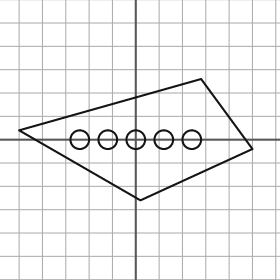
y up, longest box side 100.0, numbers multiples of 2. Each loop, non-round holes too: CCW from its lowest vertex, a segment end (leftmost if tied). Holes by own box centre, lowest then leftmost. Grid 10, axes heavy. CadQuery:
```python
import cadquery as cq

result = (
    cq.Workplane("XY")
    .moveTo(2.0, -26.0)
    .lineTo(50.0, -4.0)
    .lineTo(28.0, 26.0)
    .lineTo(-50.0, 4.0)
    .close()
    .moveTo(-24.0, 0.0)
    .circle(4.0)
    .moveTo(-12.0, 0.0)
    .circle(4.0)
    .moveTo(0.0, 0.0)
    .circle(4.0)
    .moveTo(12.0, 0.0)
    .circle(4.0)
    .moveTo(24.0, 0.0)
    .circle(4.0)
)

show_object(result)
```